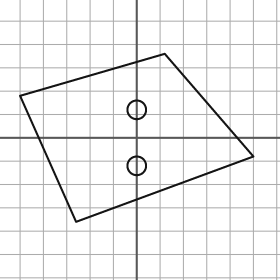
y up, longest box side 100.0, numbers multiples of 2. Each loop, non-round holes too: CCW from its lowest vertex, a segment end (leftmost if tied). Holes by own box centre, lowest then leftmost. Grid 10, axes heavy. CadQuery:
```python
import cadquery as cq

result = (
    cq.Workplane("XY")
    .moveTo(-26.0, -36.0)
    .lineTo(50.0, -8.0)
    .lineTo(12.0, 36.0)
    .lineTo(-50.0, 18.0)
    .close()
    .moveTo(0.0, -12.0)
    .circle(4.0)
    .moveTo(0.0, 12.0)
    .circle(4.0)
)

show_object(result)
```